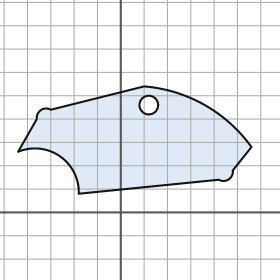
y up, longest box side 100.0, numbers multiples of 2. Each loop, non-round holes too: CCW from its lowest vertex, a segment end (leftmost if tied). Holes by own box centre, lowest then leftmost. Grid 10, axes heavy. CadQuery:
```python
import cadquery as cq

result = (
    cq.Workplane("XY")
    .moveTo(-18.0, 8.0)
    .lineTo(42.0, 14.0)
    .threePointArc((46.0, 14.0), (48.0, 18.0))
    .lineTo(56.0, 28.0)
    .threePointArc((36.0, 46.0), (10.0, 54.0))
    .lineTo(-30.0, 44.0)
    .threePointArc((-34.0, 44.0), (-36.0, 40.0))
    .lineTo(-44.0, 26.0)
    .threePointArc((-26.0, 24.0), (-18.0, 8.0))
    .close()
    .moveTo(12.0, 46.0)
    .circle(4.0)
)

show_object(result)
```